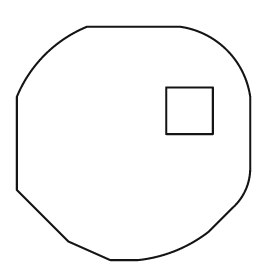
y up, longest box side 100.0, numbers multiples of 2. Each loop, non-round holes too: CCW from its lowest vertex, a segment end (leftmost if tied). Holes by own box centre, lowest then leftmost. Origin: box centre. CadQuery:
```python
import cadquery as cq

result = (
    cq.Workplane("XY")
    .moveTo(-10.0, -50.0)
    .lineTo(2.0, -50.0)
    .threePointArc((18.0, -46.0), (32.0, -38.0))
    .lineTo(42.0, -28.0)
    .threePointArc((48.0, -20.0), (50.0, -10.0))
    .lineTo(50.0, 20.0)
    .threePointArc((40.0, 40.0), (20.0, 50.0))
    .lineTo(-20.0, 50.0)
    .threePointArc((-38.0, 38.0), (-50.0, 20.0))
    .lineTo(-50.0, -20.0)
    .lineTo(-28.0, -42.0)
    .close()
    .moveTo(14.0, 4.0)
    .lineTo(34.0, 4.0)
    .lineTo(34.0, 24.0)
    .lineTo(14.0, 24.0)
    .close()
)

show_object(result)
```